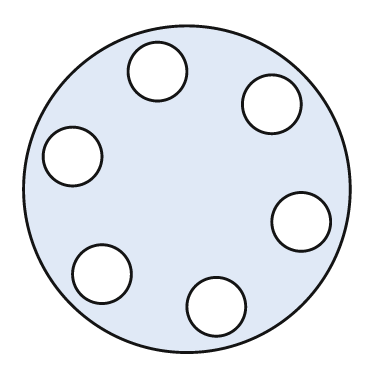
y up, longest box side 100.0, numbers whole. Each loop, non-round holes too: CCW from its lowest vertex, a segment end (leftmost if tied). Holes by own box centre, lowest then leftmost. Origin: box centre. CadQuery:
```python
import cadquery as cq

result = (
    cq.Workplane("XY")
    .moveTo(0.0, 0.0)
    .circle(50.0)
    .moveTo(9.0, -36.0)
    .circle(9.0)
    .moveTo(-26.0, -26.0)
    .circle(9.0)
    .moveTo(35.0, -10.0)
    .circle(9.0)
    .moveTo(-35.0, 10.0)
    .circle(9.0)
    .moveTo(26.0, 26.0)
    .circle(9.0)
    .moveTo(-9.0, 36.0)
    .circle(9.0)
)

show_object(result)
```